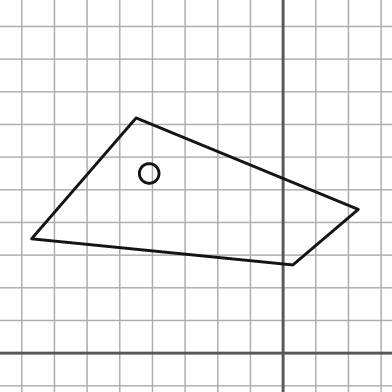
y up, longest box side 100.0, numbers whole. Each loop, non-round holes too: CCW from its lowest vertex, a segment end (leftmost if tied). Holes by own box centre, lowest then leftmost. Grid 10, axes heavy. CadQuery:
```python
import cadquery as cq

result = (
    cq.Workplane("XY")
    .moveTo(3.0, 27.0)
    .lineTo(23.0, 44.0)
    .lineTo(-45.0, 72.0)
    .lineTo(-77.0, 35.0)
    .close()
    .moveTo(-41.0, 55.0)
    .circle(3.0)
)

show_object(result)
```